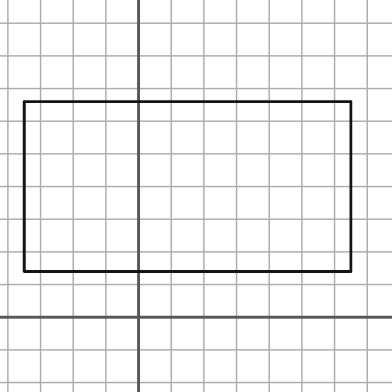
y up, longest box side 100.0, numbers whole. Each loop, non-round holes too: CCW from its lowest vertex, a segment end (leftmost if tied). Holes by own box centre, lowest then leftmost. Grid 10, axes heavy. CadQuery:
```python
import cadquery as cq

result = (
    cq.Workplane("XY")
    .moveTo(-35.0, 14.0)
    .lineTo(65.0, 14.0)
    .lineTo(65.0, 66.0)
    .lineTo(-35.0, 66.0)
    .close()
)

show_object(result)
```